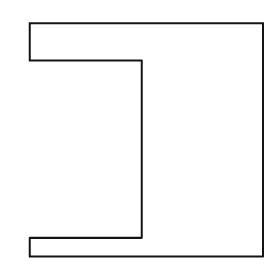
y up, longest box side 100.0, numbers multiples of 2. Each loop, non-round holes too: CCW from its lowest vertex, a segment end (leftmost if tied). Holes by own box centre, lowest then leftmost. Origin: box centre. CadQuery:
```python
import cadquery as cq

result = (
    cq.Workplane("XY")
    .moveTo(-50.0, -50.0)
    .lineTo(50.0, -50.0)
    .lineTo(50.0, 50.0)
    .lineTo(-50.0, 50.0)
    .lineTo(-50.0, 34.0)
    .lineTo(-2.0, 34.0)
    .lineTo(-2.0, -42.0)
    .lineTo(-50.0, -42.0)
    .close()
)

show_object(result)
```